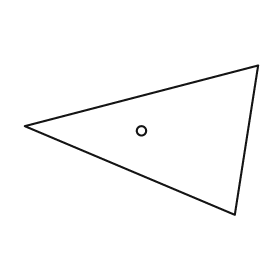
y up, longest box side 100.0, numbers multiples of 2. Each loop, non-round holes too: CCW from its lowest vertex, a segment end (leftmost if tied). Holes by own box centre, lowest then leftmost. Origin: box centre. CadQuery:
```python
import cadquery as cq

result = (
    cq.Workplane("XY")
    .moveTo(40.0, -32.0)
    .lineTo(50.0, 32.0)
    .lineTo(-50.0, 6.0)
    .close()
    .moveTo(0.0, 4.0)
    .circle(2.0)
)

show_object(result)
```